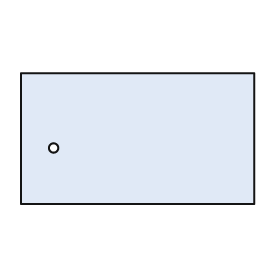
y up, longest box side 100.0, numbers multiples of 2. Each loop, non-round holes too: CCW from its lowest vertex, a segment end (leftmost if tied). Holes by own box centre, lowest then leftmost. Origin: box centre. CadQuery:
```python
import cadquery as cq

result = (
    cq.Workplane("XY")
    .moveTo(-50.0, -28.0)
    .lineTo(50.0, -28.0)
    .lineTo(50.0, 28.0)
    .lineTo(-50.0, 28.0)
    .close()
    .moveTo(-36.0, -4.0)
    .circle(2.0)
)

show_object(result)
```